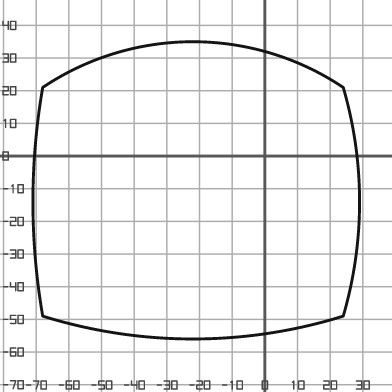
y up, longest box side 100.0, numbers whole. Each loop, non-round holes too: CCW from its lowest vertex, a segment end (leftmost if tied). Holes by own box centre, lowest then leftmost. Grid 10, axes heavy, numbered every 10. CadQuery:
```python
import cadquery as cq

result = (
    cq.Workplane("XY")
    .moveTo(-68.0, -49.0)
    .threePointArc((-22.0, -56.0), (24.0, -49.0))
    .threePointArc((29.0, -14.0), (24.0, 21.0))
    .threePointArc((-22.0, 35.0), (-68.0, 21.0))
    .threePointArc((-71.0, -14.0), (-68.0, -49.0))
    .close()
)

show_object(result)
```